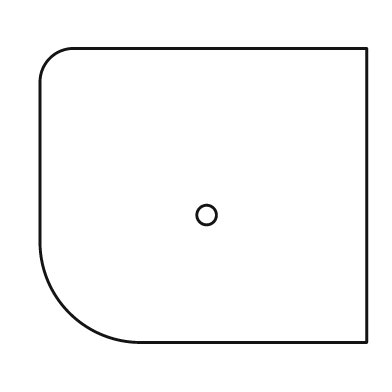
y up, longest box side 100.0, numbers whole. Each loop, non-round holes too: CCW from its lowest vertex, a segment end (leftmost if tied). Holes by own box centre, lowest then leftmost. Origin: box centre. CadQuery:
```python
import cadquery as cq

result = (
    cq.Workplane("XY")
    .moveTo(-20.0, -45.0)
    .lineTo(50.0, -45.0)
    .lineTo(50.0, 45.0)
    .lineTo(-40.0, 45.0)
    .threePointArc((-47.0, 42.0), (-50.0, 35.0))
    .lineTo(-50.0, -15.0)
    .threePointArc((-41.0, -36.0), (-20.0, -45.0))
    .close()
    .moveTo(1.0, -6.0)
    .circle(3.0)
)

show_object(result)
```